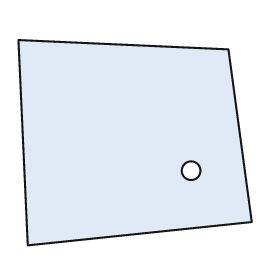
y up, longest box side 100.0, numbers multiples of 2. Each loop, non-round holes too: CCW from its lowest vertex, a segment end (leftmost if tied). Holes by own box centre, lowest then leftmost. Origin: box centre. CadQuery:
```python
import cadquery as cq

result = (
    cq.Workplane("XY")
    .moveTo(-46.0, -44.0)
    .lineTo(50.0, -34.0)
    .lineTo(40.0, 40.0)
    .lineTo(-50.0, 44.0)
    .close()
    .moveTo(24.0, -12.0)
    .circle(4.0)
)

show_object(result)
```